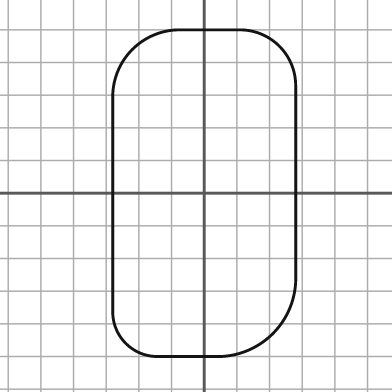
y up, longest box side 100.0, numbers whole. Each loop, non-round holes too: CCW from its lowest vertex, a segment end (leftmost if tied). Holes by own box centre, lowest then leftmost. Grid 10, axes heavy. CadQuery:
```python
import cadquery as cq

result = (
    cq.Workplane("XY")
    .moveTo(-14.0, -50.0)
    .lineTo(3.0, -50.0)
    .threePointArc((21.0, -43.0), (28.0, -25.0))
    .lineTo(28.0, 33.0)
    .threePointArc((23.0, 45.0), (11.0, 50.0))
    .lineTo(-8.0, 50.0)
    .threePointArc((-22.0, 44.0), (-28.0, 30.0))
    .lineTo(-28.0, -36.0)
    .threePointArc((-24.0, -46.0), (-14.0, -50.0))
    .close()
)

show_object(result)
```